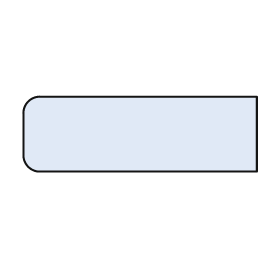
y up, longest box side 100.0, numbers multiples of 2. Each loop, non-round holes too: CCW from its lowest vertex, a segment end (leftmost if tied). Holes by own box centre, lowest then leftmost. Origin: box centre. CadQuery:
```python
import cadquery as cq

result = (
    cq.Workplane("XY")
    .moveTo(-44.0, -16.0)
    .lineTo(50.0, -16.0)
    .lineTo(50.0, 16.0)
    .lineTo(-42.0, 16.0)
    .threePointArc((-48.0, 14.0), (-50.0, 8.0))
    .lineTo(-50.0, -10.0)
    .threePointArc((-48.0, -14.0), (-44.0, -16.0))
    .close()
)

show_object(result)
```